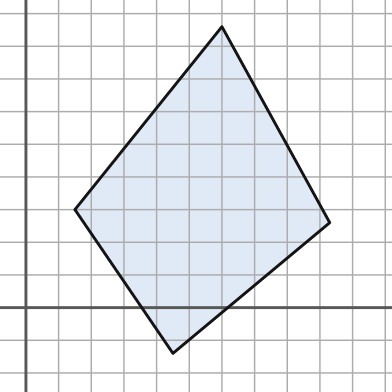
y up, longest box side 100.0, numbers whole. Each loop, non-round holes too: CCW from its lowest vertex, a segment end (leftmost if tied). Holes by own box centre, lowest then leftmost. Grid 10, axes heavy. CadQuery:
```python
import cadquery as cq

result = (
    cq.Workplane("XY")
    .moveTo(45.0, -14.0)
    .lineTo(93.0, 26.0)
    .lineTo(60.0, 86.0)
    .lineTo(15.0, 30.0)
    .close()
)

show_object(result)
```